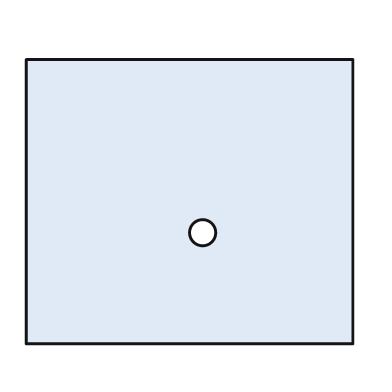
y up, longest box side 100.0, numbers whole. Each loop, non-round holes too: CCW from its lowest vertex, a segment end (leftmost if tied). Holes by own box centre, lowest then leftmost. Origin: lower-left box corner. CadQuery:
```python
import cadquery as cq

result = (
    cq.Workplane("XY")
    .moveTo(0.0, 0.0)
    .lineTo(100.0, 0.0)
    .lineTo(100.0, 87.0)
    .lineTo(0.0, 87.0)
    .close()
    .moveTo(54.0, 34.0)
    .circle(4.0)
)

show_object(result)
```